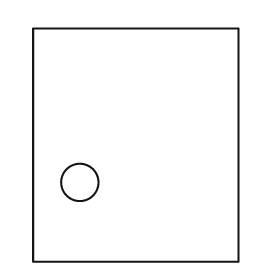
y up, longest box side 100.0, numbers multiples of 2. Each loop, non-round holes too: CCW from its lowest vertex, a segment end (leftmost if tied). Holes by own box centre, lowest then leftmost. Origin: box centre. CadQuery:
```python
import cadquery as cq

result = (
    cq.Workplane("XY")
    .moveTo(-44.0, -50.0)
    .lineTo(44.0, -50.0)
    .lineTo(44.0, 50.0)
    .lineTo(-44.0, 50.0)
    .close()
    .moveTo(-24.0, -16.0)
    .circle(8.0)
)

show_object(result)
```